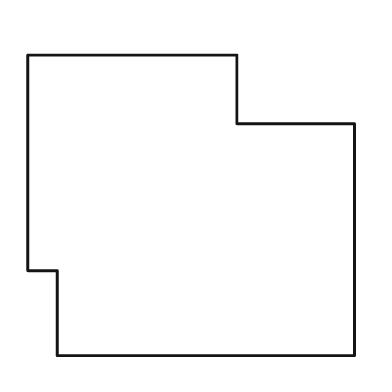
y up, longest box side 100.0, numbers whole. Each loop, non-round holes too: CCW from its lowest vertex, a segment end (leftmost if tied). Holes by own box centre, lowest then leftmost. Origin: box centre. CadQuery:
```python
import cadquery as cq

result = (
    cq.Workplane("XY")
    .moveTo(-41.0, -46.0)
    .lineTo(50.0, -46.0)
    .lineTo(50.0, 25.0)
    .lineTo(14.0, 25.0)
    .lineTo(14.0, 46.0)
    .lineTo(-50.0, 46.0)
    .lineTo(-50.0, -20.0)
    .lineTo(-41.0, -20.0)
    .close()
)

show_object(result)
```